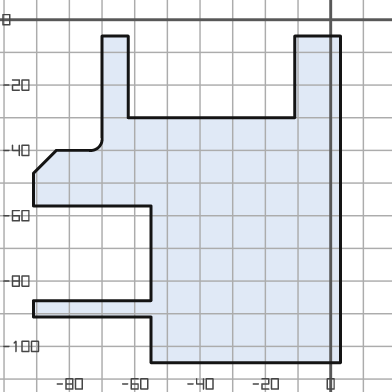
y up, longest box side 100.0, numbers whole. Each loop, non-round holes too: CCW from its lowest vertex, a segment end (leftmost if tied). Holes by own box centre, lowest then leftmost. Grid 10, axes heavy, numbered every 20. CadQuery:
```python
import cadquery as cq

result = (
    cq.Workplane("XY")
    .moveTo(-55.0, -105.0)
    .lineTo(3.0, -105.0)
    .lineTo(3.0, -5.0)
    .lineTo(-11.0, -5.0)
    .lineTo(-11.0, -30.0)
    .lineTo(-62.0, -30.0)
    .lineTo(-62.0, -5.0)
    .lineTo(-70.0, -5.0)
    .lineTo(-70.0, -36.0)
    .threePointArc((-71.0, -39.0), (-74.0, -40.0))
    .lineTo(-84.0, -40.0)
    .lineTo(-91.0, -47.0)
    .lineTo(-91.0, -57.0)
    .lineTo(-55.0, -57.0)
    .lineTo(-55.0, -86.0)
    .lineTo(-91.0, -86.0)
    .lineTo(-91.0, -91.0)
    .lineTo(-55.0, -91.0)
    .close()
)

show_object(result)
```